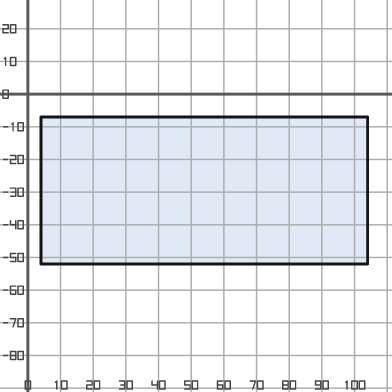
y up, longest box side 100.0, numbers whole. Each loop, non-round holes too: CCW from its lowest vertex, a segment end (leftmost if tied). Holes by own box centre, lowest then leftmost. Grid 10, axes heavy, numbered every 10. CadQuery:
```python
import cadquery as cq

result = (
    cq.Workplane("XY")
    .moveTo(4.0, -52.0)
    .lineTo(104.0, -52.0)
    .lineTo(104.0, -7.0)
    .lineTo(4.0, -7.0)
    .close()
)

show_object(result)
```